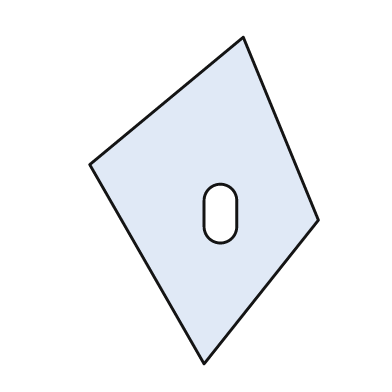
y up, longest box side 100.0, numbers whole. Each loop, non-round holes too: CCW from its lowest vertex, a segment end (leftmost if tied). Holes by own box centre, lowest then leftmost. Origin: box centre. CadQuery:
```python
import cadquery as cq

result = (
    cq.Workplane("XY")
    .moveTo(0.0, -50.0)
    .lineTo(35.0, -6.0)
    .lineTo(12.0, 50.0)
    .lineTo(-35.0, 11.0)
    .close()
    .moveTo(0.0, -8.0)
    .threePointArc((5.0, -13.0), (10.0, -8.0))
    .lineTo(10.0, 0.0)
    .threePointArc((5.0, 5.0), (0.0, 0.0))
    .close()
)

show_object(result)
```